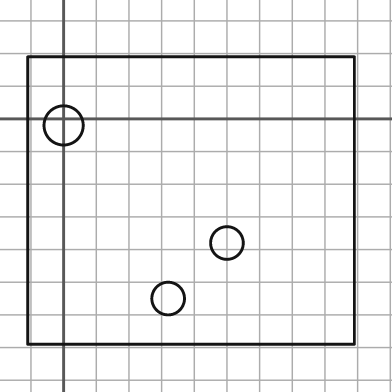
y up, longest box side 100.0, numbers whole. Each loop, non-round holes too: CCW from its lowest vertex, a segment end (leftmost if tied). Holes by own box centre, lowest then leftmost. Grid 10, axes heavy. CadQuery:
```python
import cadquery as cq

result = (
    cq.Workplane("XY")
    .moveTo(-11.0, -69.0)
    .lineTo(89.0, -69.0)
    .lineTo(89.0, 19.0)
    .lineTo(-11.0, 19.0)
    .close()
    .moveTo(32.0, -55.0)
    .circle(5.0)
    .moveTo(50.0, -38.0)
    .circle(5.0)
    .moveTo(0.0, -2.0)
    .circle(6.0)
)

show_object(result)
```